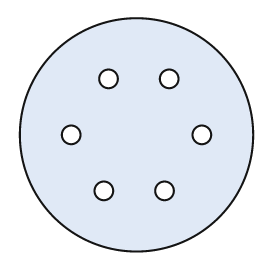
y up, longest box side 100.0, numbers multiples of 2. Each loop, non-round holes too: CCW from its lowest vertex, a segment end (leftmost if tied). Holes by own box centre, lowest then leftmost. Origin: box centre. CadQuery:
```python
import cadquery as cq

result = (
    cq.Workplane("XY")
    .moveTo(0.0, 0.0)
    .circle(50.0)
    .moveTo(-14.0, -24.0)
    .circle(4.0)
    .moveTo(12.0, -24.0)
    .circle(4.0)
    .moveTo(-28.0, 0.0)
    .circle(4.0)
    .moveTo(28.0, 0.0)
    .circle(4.0)
    .moveTo(-12.0, 24.0)
    .circle(4.0)
    .moveTo(14.0, 24.0)
    .circle(4.0)
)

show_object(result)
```